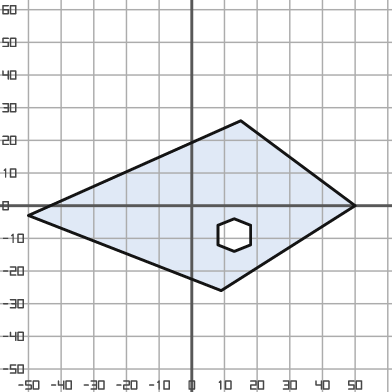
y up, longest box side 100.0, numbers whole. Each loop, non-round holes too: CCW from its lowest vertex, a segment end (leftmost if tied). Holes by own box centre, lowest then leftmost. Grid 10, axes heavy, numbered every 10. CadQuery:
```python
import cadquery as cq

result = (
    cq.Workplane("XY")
    .moveTo(9.0, -26.0)
    .lineTo(50.0, 0.0)
    .lineTo(15.0, 26.0)
    .lineTo(-50.0, -3.0)
    .close()
    .moveTo(13.0, -14.0)
    .lineTo(18.0, -12.0)
    .lineTo(18.0, -6.0)
    .lineTo(13.0, -4.0)
    .lineTo(8.0, -6.0)
    .lineTo(8.0, -12.0)
    .close()
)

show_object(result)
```